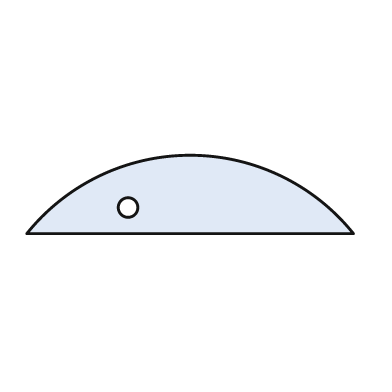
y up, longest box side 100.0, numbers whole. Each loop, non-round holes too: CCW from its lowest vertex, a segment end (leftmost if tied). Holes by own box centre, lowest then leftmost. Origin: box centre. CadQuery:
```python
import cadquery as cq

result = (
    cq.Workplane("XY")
    .moveTo(-50.0, -12.0)
    .lineTo(50.0, -12.0)
    .threePointArc((0.0, 12.0), (-50.0, -12.0))
    .close()
    .moveTo(-19.0, -4.0)
    .circle(3.0)
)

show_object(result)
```